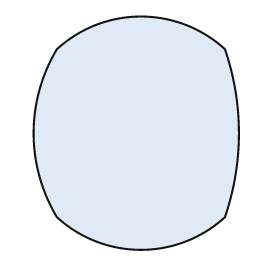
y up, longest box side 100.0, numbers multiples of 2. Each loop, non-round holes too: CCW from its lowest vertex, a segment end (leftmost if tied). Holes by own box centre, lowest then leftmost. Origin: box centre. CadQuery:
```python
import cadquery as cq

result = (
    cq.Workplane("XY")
    .moveTo(-34.0, -36.0)
    .threePointArc((2.0, -50.0), (38.0, -36.0))
    .threePointArc((44.0, 0.0), (38.0, 36.0))
    .threePointArc((2.0, 50.0), (-34.0, 36.0))
    .threePointArc((-44.0, 0.0), (-34.0, -36.0))
    .close()
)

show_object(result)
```